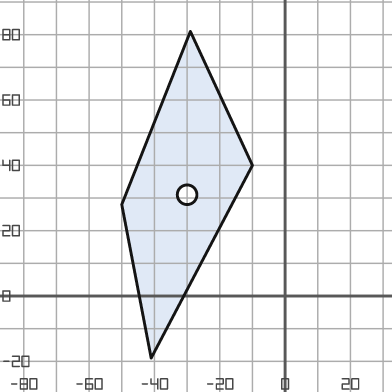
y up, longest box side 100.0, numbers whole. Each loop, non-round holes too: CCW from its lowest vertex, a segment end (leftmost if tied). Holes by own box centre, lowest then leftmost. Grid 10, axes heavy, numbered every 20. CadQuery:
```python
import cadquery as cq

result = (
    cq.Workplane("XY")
    .moveTo(-41.0, -19.0)
    .lineTo(-10.0, 40.0)
    .lineTo(-29.0, 81.0)
    .lineTo(-50.0, 28.0)
    .close()
    .moveTo(-30.0, 31.0)
    .circle(3.0)
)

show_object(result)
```